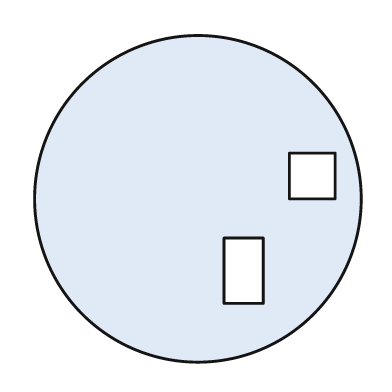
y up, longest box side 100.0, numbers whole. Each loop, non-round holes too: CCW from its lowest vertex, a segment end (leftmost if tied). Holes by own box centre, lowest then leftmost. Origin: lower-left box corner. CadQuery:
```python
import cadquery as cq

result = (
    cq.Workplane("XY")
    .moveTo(50.0, 50.0)
    .circle(50.0)
    .moveTo(58.0, 18.0)
    .lineTo(70.0, 18.0)
    .lineTo(70.0, 38.0)
    .lineTo(58.0, 38.0)
    .close()
    .moveTo(78.0, 50.0)
    .lineTo(92.0, 50.0)
    .lineTo(92.0, 64.0)
    .lineTo(78.0, 64.0)
    .close()
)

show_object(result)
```